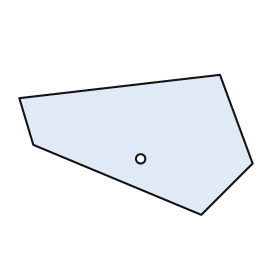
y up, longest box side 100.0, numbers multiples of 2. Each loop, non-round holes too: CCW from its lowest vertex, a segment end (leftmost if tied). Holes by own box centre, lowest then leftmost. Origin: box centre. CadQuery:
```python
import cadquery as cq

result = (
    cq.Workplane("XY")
    .moveTo(28.0, -30.0)
    .lineTo(50.0, -8.0)
    .lineTo(36.0, 30.0)
    .lineTo(-50.0, 20.0)
    .lineTo(-44.0, 0.0)
    .close()
    .moveTo(2.0, -6.0)
    .circle(2.0)
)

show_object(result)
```